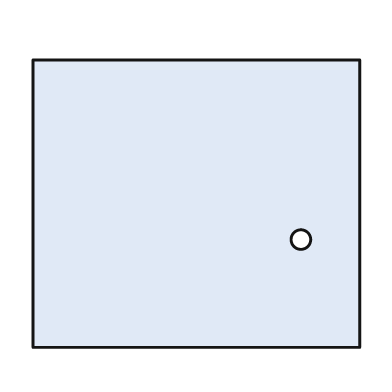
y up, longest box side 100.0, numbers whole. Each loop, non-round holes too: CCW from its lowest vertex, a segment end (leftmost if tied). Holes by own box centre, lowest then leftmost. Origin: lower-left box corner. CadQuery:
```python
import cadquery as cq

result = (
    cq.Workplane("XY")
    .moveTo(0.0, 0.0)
    .lineTo(100.0, 0.0)
    .lineTo(100.0, 88.0)
    .lineTo(0.0, 88.0)
    .close()
    .moveTo(82.0, 33.0)
    .circle(3.0)
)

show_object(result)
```